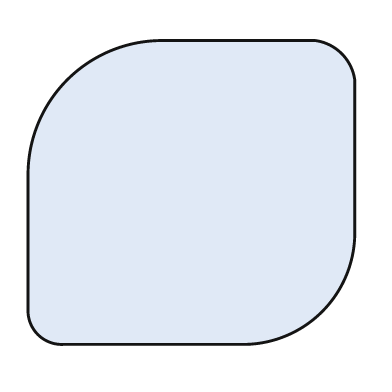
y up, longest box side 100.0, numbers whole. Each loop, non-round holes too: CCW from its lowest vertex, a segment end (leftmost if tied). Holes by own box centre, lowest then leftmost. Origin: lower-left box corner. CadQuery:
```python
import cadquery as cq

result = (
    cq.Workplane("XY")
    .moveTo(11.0, 0.0)
    .lineTo(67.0, 0.0)
    .threePointArc((90.0, 10.0), (100.0, 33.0))
    .lineTo(100.0, 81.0)
    .threePointArc((96.0, 89.0), (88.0, 93.0))
    .lineTo(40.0, 93.0)
    .threePointArc((12.0, 81.0), (0.0, 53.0))
    .lineTo(0.0, 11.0)
    .threePointArc((3.0, 3.0), (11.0, 0.0))
    .close()
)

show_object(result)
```